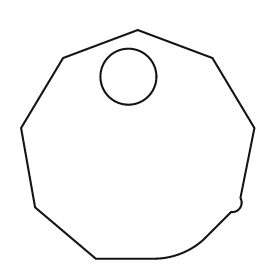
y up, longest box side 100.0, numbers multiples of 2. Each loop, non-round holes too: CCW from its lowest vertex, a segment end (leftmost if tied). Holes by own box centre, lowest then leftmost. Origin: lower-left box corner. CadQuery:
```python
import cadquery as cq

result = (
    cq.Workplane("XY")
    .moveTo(32.0, 0.0)
    .lineTo(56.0, 0.0)
    .threePointArc((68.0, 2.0), (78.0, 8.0))
    .lineTo(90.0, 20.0)
    .threePointArc((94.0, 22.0), (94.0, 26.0))
    .lineTo(100.0, 56.0)
    .lineTo(82.0, 86.0)
    .lineTo(50.0, 98.0)
    .lineTo(18.0, 86.0)
    .lineTo(0.0, 56.0)
    .lineTo(6.0, 22.0)
    .close()
    .moveTo(46.0, 78.0)
    .circle(12.0)
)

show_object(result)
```